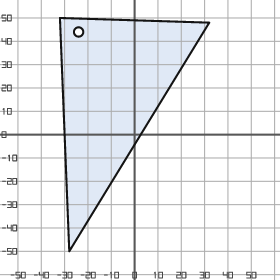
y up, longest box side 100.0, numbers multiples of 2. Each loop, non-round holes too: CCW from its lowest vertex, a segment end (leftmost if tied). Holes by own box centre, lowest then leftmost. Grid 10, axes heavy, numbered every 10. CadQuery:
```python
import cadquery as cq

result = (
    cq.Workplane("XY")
    .moveTo(-28.0, -50.0)
    .lineTo(32.0, 48.0)
    .lineTo(-32.0, 50.0)
    .close()
    .moveTo(-24.0, 44.0)
    .circle(2.0)
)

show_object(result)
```